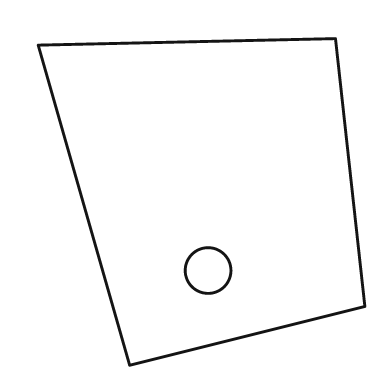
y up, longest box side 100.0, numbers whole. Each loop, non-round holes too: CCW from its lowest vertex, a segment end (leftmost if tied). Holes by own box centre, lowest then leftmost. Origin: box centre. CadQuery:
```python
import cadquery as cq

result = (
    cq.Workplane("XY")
    .moveTo(-22.0, -50.0)
    .lineTo(50.0, -32.0)
    .lineTo(41.0, 50.0)
    .lineTo(-50.0, 48.0)
    .close()
    .moveTo(2.0, -21.0)
    .circle(7.0)
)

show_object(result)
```